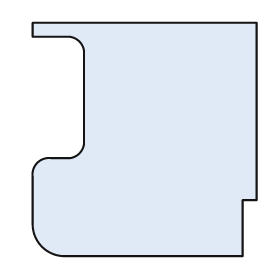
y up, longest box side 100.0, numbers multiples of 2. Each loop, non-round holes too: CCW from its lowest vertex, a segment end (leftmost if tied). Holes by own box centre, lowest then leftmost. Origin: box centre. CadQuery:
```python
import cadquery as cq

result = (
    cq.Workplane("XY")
    .moveTo(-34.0, -50.0)
    .lineTo(42.0, -50.0)
    .lineTo(42.0, -26.0)
    .lineTo(48.0, -26.0)
    .lineTo(48.0, 50.0)
    .lineTo(-48.0, 50.0)
    .lineTo(-48.0, 44.0)
    .lineTo(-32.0, 44.0)
    .threePointArc((-28.0, 42.0), (-26.0, 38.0))
    .lineTo(-26.0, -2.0)
    .threePointArc((-28.0, -6.0), (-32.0, -8.0))
    .lineTo(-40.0, -8.0)
    .threePointArc((-46.0, -10.0), (-48.0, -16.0))
    .lineTo(-48.0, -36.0)
    .threePointArc((-44.0, -46.0), (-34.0, -50.0))
    .close()
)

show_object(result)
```